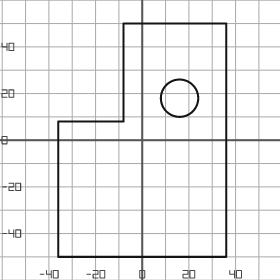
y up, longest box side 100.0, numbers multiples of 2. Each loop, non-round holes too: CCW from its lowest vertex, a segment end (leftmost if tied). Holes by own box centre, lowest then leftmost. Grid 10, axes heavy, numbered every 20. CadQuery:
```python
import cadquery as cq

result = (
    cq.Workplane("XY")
    .moveTo(-36.0, -50.0)
    .lineTo(36.0, -50.0)
    .lineTo(36.0, 50.0)
    .lineTo(-8.0, 50.0)
    .lineTo(-8.0, 8.0)
    .lineTo(-36.0, 8.0)
    .close()
    .moveTo(16.0, 18.0)
    .circle(8.0)
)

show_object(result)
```